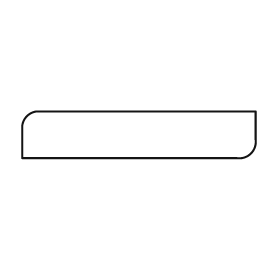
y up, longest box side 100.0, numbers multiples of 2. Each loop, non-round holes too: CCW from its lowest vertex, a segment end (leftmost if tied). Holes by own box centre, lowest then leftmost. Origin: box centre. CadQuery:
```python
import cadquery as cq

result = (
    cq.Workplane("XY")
    .moveTo(-50.0, -10.0)
    .lineTo(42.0, -10.0)
    .threePointArc((48.0, -8.0), (50.0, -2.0))
    .lineTo(50.0, 10.0)
    .lineTo(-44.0, 10.0)
    .threePointArc((-48.0, 8.0), (-50.0, 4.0))
    .close()
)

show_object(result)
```